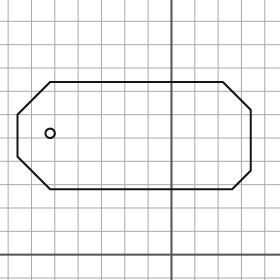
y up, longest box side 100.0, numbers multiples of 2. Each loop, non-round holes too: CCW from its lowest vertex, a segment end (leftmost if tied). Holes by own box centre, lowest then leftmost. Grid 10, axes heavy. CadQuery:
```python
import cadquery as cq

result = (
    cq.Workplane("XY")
    .moveTo(-52.0, 28.0)
    .lineTo(26.0, 28.0)
    .lineTo(34.0, 36.0)
    .lineTo(34.0, 62.0)
    .lineTo(22.0, 74.0)
    .lineTo(-52.0, 74.0)
    .lineTo(-66.0, 60.0)
    .lineTo(-66.0, 42.0)
    .close()
    .moveTo(-52.0, 52.0)
    .circle(2.0)
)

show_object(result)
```